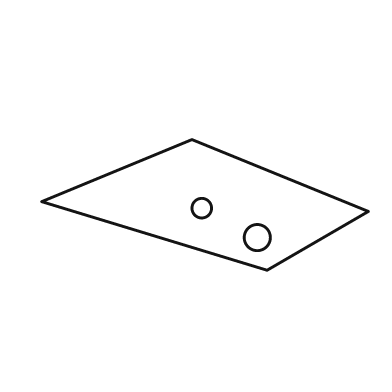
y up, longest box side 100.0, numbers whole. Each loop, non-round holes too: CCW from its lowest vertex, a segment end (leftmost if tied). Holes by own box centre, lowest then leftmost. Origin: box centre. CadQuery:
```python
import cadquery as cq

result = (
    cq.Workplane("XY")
    .moveTo(19.0, -20.0)
    .lineTo(50.0, -2.0)
    .lineTo(-4.0, 20.0)
    .lineTo(-50.0, 1.0)
    .close()
    .moveTo(16.0, -10.0)
    .circle(4.0)
    .moveTo(-1.0, -1.0)
    .circle(3.0)
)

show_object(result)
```